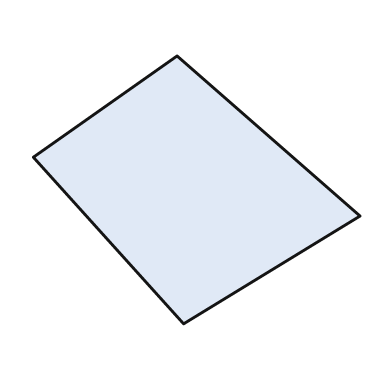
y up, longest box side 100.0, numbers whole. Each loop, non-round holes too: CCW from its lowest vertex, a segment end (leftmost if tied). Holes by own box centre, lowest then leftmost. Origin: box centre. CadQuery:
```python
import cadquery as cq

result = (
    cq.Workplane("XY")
    .moveTo(-4.0, -41.0)
    .lineTo(50.0, -8.0)
    .lineTo(-6.0, 41.0)
    .lineTo(-50.0, 10.0)
    .close()
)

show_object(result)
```